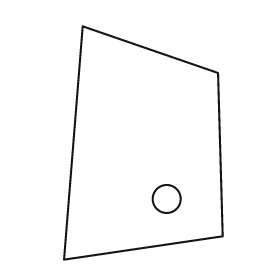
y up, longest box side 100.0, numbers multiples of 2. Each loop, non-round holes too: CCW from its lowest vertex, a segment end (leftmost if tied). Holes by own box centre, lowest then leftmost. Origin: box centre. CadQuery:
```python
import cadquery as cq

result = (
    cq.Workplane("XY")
    .moveTo(-34.0, -50.0)
    .lineTo(34.0, -40.0)
    .lineTo(32.0, 30.0)
    .lineTo(-26.0, 50.0)
    .close()
    .moveTo(10.0, -24.0)
    .circle(6.0)
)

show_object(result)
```